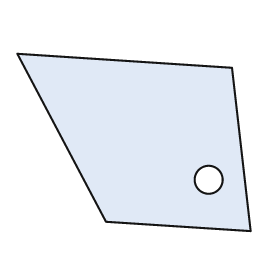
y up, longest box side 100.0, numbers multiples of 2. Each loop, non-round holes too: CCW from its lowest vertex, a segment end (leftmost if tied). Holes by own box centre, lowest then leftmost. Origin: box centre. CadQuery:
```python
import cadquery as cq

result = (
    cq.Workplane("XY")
    .moveTo(50.0, -38.0)
    .lineTo(42.0, 32.0)
    .lineTo(-50.0, 38.0)
    .lineTo(-12.0, -34.0)
    .close()
    .moveTo(32.0, -16.0)
    .circle(6.0)
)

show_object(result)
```